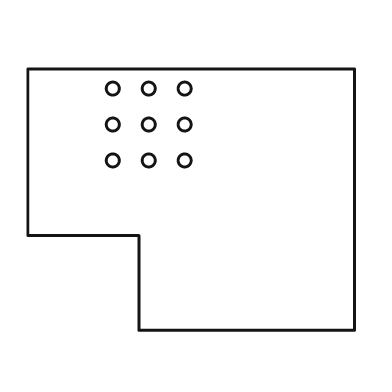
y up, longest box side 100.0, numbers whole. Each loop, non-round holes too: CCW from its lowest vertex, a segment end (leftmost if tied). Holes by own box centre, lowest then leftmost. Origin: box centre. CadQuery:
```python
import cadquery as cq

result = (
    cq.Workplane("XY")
    .moveTo(-16.0, -40.0)
    .lineTo(50.0, -40.0)
    .lineTo(50.0, 40.0)
    .lineTo(-50.0, 40.0)
    .lineTo(-50.0, -11.0)
    .lineTo(-16.0, -11.0)
    .close()
    .moveTo(-24.0, 12.0)
    .circle(2.0)
    .moveTo(-13.0, 12.0)
    .circle(2.0)
    .moveTo(-2.0, 12.0)
    .circle(2.0)
    .moveTo(-24.0, 23.0)
    .circle(2.0)
    .moveTo(-13.0, 23.0)
    .circle(2.0)
    .moveTo(-2.0, 23.0)
    .circle(2.0)
    .moveTo(-24.0, 34.0)
    .circle(2.0)
    .moveTo(-13.0, 34.0)
    .circle(2.0)
    .moveTo(-2.0, 34.0)
    .circle(2.0)
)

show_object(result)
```